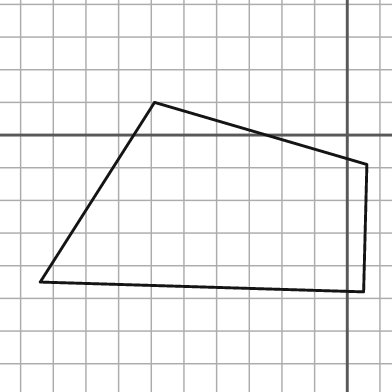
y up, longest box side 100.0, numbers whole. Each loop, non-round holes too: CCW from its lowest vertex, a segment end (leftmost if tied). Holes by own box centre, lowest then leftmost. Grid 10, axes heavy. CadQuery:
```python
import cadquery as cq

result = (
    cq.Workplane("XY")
    .moveTo(5.0, -48.0)
    .lineTo(6.0, -9.0)
    .lineTo(-59.0, 10.0)
    .lineTo(-94.0, -45.0)
    .close()
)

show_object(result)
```